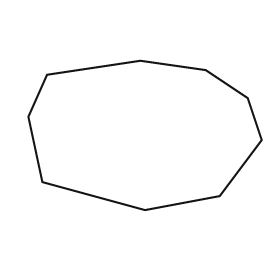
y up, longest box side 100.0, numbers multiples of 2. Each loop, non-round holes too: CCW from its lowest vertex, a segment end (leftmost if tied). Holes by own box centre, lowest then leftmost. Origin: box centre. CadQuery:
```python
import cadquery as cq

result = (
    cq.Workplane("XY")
    .moveTo(0.0, -32.0)
    .lineTo(32.0, -26.0)
    .lineTo(50.0, -2.0)
    .lineTo(44.0, 16.0)
    .lineTo(26.0, 28.0)
    .lineTo(-2.0, 32.0)
    .lineTo(-42.0, 26.0)
    .lineTo(-50.0, 8.0)
    .lineTo(-44.0, -20.0)
    .close()
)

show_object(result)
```